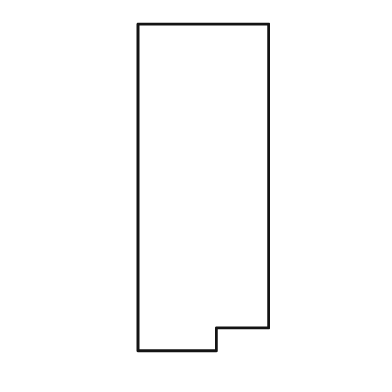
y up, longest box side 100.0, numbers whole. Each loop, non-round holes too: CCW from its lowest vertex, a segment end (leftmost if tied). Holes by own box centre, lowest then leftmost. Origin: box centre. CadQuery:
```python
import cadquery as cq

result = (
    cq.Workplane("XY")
    .moveTo(-20.0, -50.0)
    .lineTo(4.0, -50.0)
    .lineTo(4.0, -43.0)
    .lineTo(20.0, -43.0)
    .lineTo(20.0, 50.0)
    .lineTo(-20.0, 50.0)
    .close()
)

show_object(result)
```